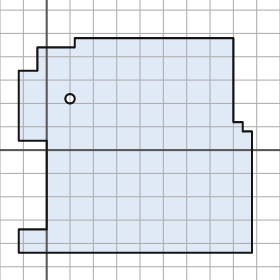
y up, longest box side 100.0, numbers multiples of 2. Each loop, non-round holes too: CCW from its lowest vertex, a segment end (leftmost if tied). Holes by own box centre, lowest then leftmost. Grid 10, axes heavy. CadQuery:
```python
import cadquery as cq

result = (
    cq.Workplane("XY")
    .moveTo(-12.0, -44.0)
    .lineTo(88.0, -44.0)
    .lineTo(88.0, 8.0)
    .lineTo(84.0, 8.0)
    .lineTo(84.0, 12.0)
    .lineTo(80.0, 12.0)
    .lineTo(80.0, 48.0)
    .lineTo(12.0, 48.0)
    .lineTo(12.0, 44.0)
    .lineTo(-4.0, 44.0)
    .lineTo(-4.0, 34.0)
    .lineTo(-12.0, 34.0)
    .lineTo(-12.0, 4.0)
    .lineTo(0.0, 4.0)
    .lineTo(0.0, -34.0)
    .lineTo(-12.0, -34.0)
    .close()
    .moveTo(10.0, 22.0)
    .circle(2.0)
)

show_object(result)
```